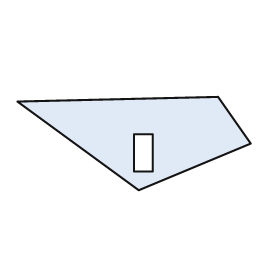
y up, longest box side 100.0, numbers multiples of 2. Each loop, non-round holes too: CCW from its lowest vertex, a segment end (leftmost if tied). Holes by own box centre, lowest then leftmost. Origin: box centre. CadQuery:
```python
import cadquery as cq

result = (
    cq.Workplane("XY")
    .moveTo(2.0, -20.0)
    .lineTo(50.0, 0.0)
    .lineTo(36.0, 20.0)
    .lineTo(-50.0, 18.0)
    .close()
    .moveTo(0.0, -12.0)
    .lineTo(8.0, -12.0)
    .lineTo(8.0, 4.0)
    .lineTo(0.0, 4.0)
    .close()
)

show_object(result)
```